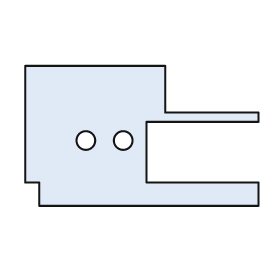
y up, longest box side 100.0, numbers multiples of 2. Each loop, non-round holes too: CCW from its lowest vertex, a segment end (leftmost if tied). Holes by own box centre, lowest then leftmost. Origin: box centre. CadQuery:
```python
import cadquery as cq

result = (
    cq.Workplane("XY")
    .moveTo(-44.0, -30.0)
    .lineTo(50.0, -30.0)
    .lineTo(50.0, -20.0)
    .lineTo(2.0, -20.0)
    .lineTo(2.0, 6.0)
    .lineTo(50.0, 6.0)
    .lineTo(50.0, 10.0)
    .lineTo(10.0, 10.0)
    .lineTo(10.0, 30.0)
    .lineTo(-50.0, 30.0)
    .lineTo(-50.0, -20.0)
    .lineTo(-44.0, -20.0)
    .close()
    .moveTo(-24.0, -2.0)
    .circle(4.0)
    .moveTo(-8.0, -2.0)
    .circle(4.0)
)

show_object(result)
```